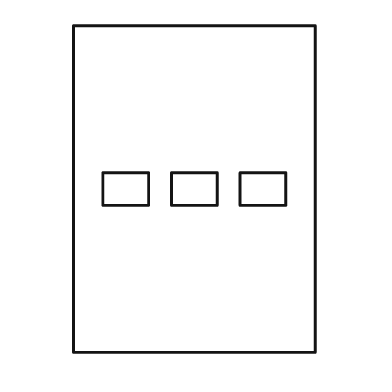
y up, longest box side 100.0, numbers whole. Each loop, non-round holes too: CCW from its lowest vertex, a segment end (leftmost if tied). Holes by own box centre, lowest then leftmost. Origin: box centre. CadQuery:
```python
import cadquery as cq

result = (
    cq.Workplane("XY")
    .moveTo(-37.0, -50.0)
    .lineTo(37.0, -50.0)
    .lineTo(37.0, 50.0)
    .lineTo(-37.0, 50.0)
    .close()
    .moveTo(-28.0, -5.0)
    .lineTo(-14.0, -5.0)
    .lineTo(-14.0, 5.0)
    .lineTo(-28.0, 5.0)
    .close()
    .moveTo(-7.0, -5.0)
    .lineTo(7.0, -5.0)
    .lineTo(7.0, 5.0)
    .lineTo(-7.0, 5.0)
    .close()
    .moveTo(14.0, -5.0)
    .lineTo(28.0, -5.0)
    .lineTo(28.0, 5.0)
    .lineTo(14.0, 5.0)
    .close()
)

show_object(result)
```